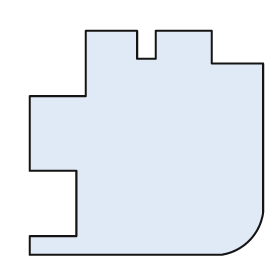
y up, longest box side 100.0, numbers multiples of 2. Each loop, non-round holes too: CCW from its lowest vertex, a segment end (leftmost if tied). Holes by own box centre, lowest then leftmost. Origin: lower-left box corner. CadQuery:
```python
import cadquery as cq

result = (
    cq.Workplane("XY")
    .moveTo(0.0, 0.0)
    .lineTo(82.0, 0.0)
    .threePointArc((94.0, 6.0), (100.0, 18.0))
    .lineTo(100.0, 82.0)
    .lineTo(78.0, 82.0)
    .lineTo(78.0, 96.0)
    .lineTo(54.0, 96.0)
    .lineTo(54.0, 84.0)
    .lineTo(46.0, 84.0)
    .lineTo(46.0, 96.0)
    .lineTo(24.0, 96.0)
    .lineTo(24.0, 68.0)
    .lineTo(0.0, 68.0)
    .lineTo(0.0, 36.0)
    .lineTo(20.0, 36.0)
    .lineTo(20.0, 8.0)
    .lineTo(0.0, 8.0)
    .close()
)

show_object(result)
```